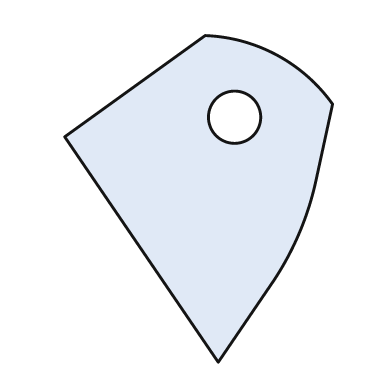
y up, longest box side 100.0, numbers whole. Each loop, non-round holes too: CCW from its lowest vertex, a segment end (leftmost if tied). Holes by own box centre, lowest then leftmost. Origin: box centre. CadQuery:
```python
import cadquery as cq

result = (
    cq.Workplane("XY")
    .moveTo(6.0, -50.0)
    .lineTo(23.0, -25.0)
    .threePointArc((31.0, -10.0), (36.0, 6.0))
    .lineTo(41.0, 29.0)
    .threePointArc((24.0, 44.0), (2.0, 50.0))
    .lineTo(-41.0, 19.0)
    .close()
    .moveTo(11.0, 25.0)
    .circle(8.0)
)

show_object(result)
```